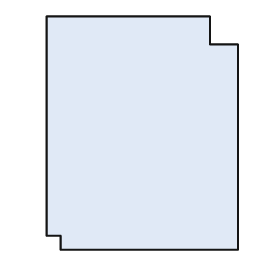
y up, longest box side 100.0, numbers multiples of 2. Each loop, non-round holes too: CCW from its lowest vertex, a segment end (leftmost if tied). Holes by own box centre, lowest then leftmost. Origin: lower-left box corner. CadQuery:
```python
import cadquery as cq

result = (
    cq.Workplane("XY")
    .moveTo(6.0, 0.0)
    .lineTo(82.0, 0.0)
    .lineTo(82.0, 88.0)
    .lineTo(70.0, 88.0)
    .lineTo(70.0, 100.0)
    .lineTo(0.0, 100.0)
    .lineTo(0.0, 6.0)
    .lineTo(6.0, 6.0)
    .close()
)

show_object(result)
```